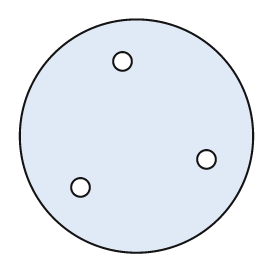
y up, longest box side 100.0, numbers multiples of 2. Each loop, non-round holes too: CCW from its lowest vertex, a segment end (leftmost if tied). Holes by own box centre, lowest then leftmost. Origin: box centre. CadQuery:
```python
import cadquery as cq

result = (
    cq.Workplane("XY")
    .moveTo(0.0, 0.0)
    .circle(50.0)
    .moveTo(-24.0, -22.0)
    .circle(4.0)
    .moveTo(30.0, -10.0)
    .circle(4.0)
    .moveTo(-6.0, 32.0)
    .circle(4.0)
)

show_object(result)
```